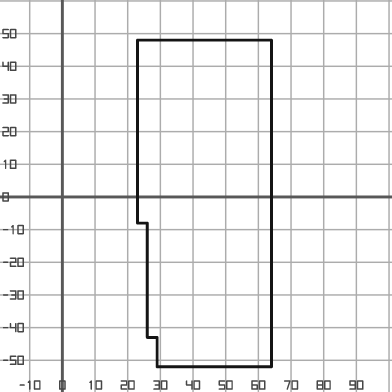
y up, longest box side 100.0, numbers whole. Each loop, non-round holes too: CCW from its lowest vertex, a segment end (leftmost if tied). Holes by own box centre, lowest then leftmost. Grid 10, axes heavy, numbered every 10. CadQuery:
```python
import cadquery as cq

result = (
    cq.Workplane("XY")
    .moveTo(29.0, -52.0)
    .lineTo(64.0, -52.0)
    .lineTo(64.0, 48.0)
    .lineTo(23.0, 48.0)
    .lineTo(23.0, -8.0)
    .lineTo(26.0, -8.0)
    .lineTo(26.0, -43.0)
    .lineTo(29.0, -43.0)
    .close()
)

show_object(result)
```